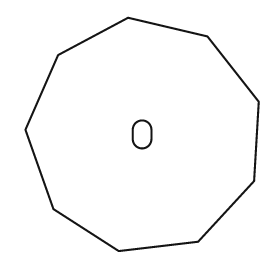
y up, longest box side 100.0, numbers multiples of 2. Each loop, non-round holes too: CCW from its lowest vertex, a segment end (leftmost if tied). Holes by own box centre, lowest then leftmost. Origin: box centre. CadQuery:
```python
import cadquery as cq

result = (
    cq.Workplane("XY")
    .moveTo(-10.0, -50.0)
    .lineTo(24.0, -46.0)
    .lineTo(48.0, -20.0)
    .lineTo(50.0, 14.0)
    .lineTo(28.0, 42.0)
    .lineTo(-6.0, 50.0)
    .lineTo(-36.0, 34.0)
    .lineTo(-50.0, 2.0)
    .lineTo(-38.0, -32.0)
    .close()
    .moveTo(-4.0, -2.0)
    .threePointArc((0.0, -6.0), (4.0, -2.0))
    .lineTo(4.0, 2.0)
    .threePointArc((0.0, 6.0), (-4.0, 2.0))
    .close()
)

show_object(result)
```